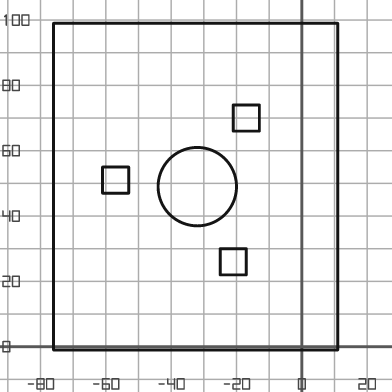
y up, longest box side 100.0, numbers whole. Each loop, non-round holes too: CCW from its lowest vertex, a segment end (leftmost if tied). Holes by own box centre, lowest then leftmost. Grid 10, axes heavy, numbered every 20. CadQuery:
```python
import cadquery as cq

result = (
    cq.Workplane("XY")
    .moveTo(-76.0, -1.0)
    .lineTo(11.0, -1.0)
    .lineTo(11.0, 99.0)
    .lineTo(-76.0, 99.0)
    .close()
    .moveTo(-25.0, 22.0)
    .lineTo(-17.0, 22.0)
    .lineTo(-17.0, 30.0)
    .lineTo(-25.0, 30.0)
    .close()
    .moveTo(-32.0, 49.0)
    .circle(12.0)
    .moveTo(-61.0, 47.0)
    .lineTo(-53.0, 47.0)
    .lineTo(-53.0, 55.0)
    .lineTo(-61.0, 55.0)
    .close()
    .moveTo(-21.0, 66.0)
    .lineTo(-13.0, 66.0)
    .lineTo(-13.0, 74.0)
    .lineTo(-21.0, 74.0)
    .close()
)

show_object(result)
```